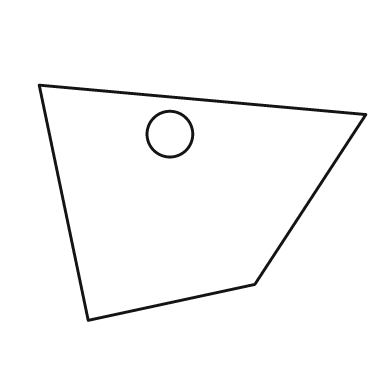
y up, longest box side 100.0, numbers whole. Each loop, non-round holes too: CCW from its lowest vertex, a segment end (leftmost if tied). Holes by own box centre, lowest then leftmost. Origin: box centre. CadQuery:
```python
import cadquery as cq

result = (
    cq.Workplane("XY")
    .moveTo(-35.0, -36.0)
    .lineTo(16.0, -25.0)
    .lineTo(50.0, 27.0)
    .lineTo(-50.0, 36.0)
    .close()
    .moveTo(-10.0, 21.0)
    .circle(7.0)
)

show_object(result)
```